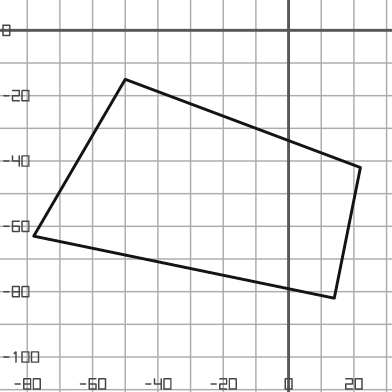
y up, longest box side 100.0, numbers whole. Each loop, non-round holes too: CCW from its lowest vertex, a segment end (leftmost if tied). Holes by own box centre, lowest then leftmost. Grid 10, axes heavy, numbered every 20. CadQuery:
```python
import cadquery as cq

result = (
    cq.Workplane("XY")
    .moveTo(14.0, -82.0)
    .lineTo(22.0, -42.0)
    .lineTo(-50.0, -15.0)
    .lineTo(-78.0, -63.0)
    .close()
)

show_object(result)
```